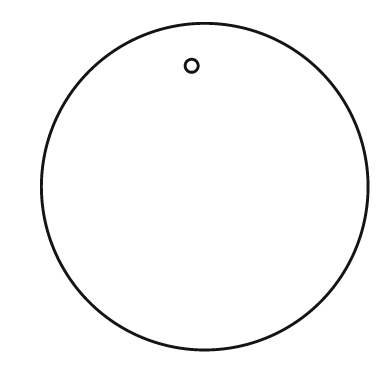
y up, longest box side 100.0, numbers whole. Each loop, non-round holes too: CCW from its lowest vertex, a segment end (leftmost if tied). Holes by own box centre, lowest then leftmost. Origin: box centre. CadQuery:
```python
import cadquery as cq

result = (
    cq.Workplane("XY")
    .moveTo(0.0, 0.0)
    .circle(50.0)
    .moveTo(-4.0, 37.0)
    .circle(2.0)
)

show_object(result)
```